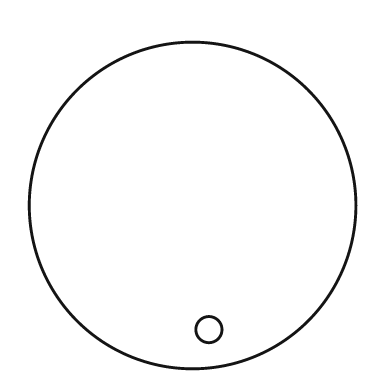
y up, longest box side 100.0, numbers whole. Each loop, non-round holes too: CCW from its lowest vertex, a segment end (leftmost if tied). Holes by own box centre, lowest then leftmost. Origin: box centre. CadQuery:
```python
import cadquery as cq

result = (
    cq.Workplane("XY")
    .moveTo(0.0, 0.0)
    .circle(50.0)
    .moveTo(5.0, -38.0)
    .circle(4.0)
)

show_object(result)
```